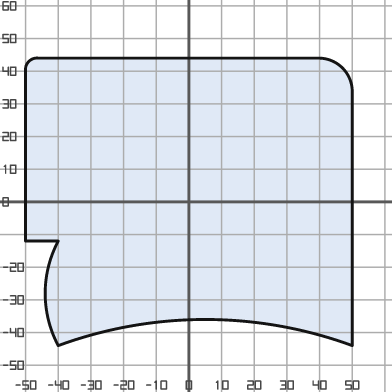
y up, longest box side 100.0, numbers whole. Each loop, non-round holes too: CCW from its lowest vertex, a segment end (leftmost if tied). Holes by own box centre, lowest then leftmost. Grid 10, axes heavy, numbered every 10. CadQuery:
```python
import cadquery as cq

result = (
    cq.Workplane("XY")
    .moveTo(-40.0, -44.0)
    .threePointArc((5.0, -36.0), (50.0, -44.0))
    .lineTo(50.0, 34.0)
    .threePointArc((47.0, 41.0), (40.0, 44.0))
    .lineTo(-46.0, 44.0)
    .threePointArc((-49.0, 43.0), (-50.0, 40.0))
    .lineTo(-50.0, -12.0)
    .lineTo(-40.0, -12.0)
    .threePointArc((-44.0, -28.0), (-40.0, -44.0))
    .close()
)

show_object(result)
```